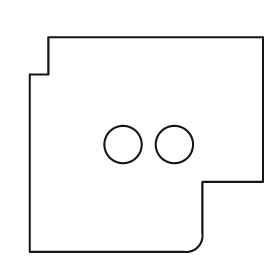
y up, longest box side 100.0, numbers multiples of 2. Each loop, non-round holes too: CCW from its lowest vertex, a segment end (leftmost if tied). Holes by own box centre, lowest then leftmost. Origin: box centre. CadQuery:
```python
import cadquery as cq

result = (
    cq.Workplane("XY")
    .moveTo(-50.0, -46.0)
    .lineTo(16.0, -46.0)
    .threePointArc((22.0, -44.0), (24.0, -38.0))
    .lineTo(24.0, -16.0)
    .lineTo(50.0, -16.0)
    .lineTo(50.0, 46.0)
    .lineTo(-42.0, 46.0)
    .lineTo(-42.0, 30.0)
    .lineTo(-50.0, 30.0)
    .close()
    .moveTo(-10.0, 0.0)
    .circle(8.0)
    .moveTo(12.0, 0.0)
    .circle(8.0)
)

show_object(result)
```